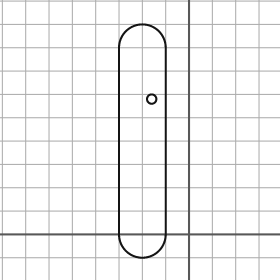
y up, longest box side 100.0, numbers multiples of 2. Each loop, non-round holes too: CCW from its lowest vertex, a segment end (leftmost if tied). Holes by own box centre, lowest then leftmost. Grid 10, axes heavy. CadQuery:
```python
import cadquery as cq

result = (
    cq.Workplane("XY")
    .moveTo(-30.0, 0.0)
    .threePointArc((-20.0, -10.0), (-10.0, 0.0))
    .lineTo(-10.0, 80.0)
    .threePointArc((-20.0, 90.0), (-30.0, 80.0))
    .close()
    .moveTo(-16.0, 58.0)
    .circle(2.0)
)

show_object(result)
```